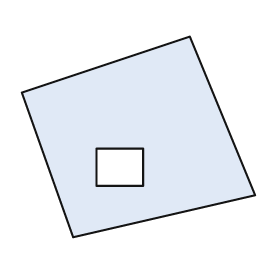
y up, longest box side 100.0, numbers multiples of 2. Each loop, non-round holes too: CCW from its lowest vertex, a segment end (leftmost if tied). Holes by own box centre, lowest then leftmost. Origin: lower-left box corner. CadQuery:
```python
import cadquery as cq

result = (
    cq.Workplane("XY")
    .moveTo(22.0, 0.0)
    .lineTo(100.0, 18.0)
    .lineTo(72.0, 86.0)
    .lineTo(0.0, 62.0)
    .close()
    .moveTo(32.0, 22.0)
    .lineTo(52.0, 22.0)
    .lineTo(52.0, 38.0)
    .lineTo(32.0, 38.0)
    .close()
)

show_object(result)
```